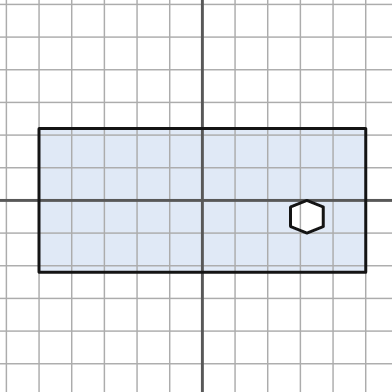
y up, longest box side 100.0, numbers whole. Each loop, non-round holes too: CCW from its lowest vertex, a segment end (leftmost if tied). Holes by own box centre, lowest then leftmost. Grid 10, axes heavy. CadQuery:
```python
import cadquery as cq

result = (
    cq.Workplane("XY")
    .moveTo(-50.0, -22.0)
    .lineTo(50.0, -22.0)
    .lineTo(50.0, 22.0)
    .lineTo(-50.0, 22.0)
    .close()
    .moveTo(32.0, -10.0)
    .lineTo(37.0, -8.0)
    .lineTo(37.0, -2.0)
    .lineTo(32.0, 0.0)
    .lineTo(27.0, -2.0)
    .lineTo(27.0, -8.0)
    .close()
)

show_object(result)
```